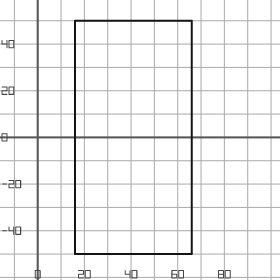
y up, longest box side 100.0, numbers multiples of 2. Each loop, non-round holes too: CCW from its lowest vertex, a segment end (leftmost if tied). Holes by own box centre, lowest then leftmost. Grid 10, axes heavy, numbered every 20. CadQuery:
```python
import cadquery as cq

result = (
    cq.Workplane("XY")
    .moveTo(16.0, -50.0)
    .lineTo(66.0, -50.0)
    .lineTo(66.0, 50.0)
    .lineTo(16.0, 50.0)
    .close()
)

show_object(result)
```